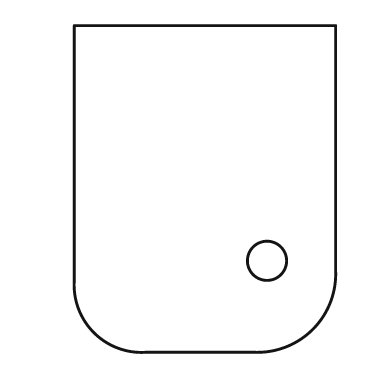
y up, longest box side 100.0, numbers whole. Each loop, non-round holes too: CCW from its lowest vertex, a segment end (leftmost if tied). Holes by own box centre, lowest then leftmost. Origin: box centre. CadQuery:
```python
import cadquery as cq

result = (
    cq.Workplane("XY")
    .moveTo(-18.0, -50.0)
    .lineTo(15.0, -50.0)
    .threePointArc((33.0, -43.0), (40.0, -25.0))
    .lineTo(40.0, 50.0)
    .lineTo(-40.0, 50.0)
    .lineTo(-40.0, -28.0)
    .threePointArc((-34.0, -44.0), (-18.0, -50.0))
    .close()
    .moveTo(19.0, -22.0)
    .circle(6.0)
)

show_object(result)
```